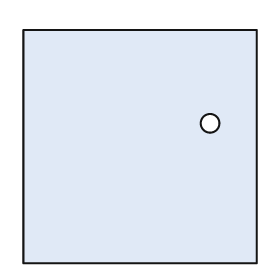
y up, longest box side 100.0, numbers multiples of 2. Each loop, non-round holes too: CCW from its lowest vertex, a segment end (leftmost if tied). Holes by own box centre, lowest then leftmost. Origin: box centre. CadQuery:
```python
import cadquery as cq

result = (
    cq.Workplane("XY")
    .moveTo(-50.0, -50.0)
    .lineTo(50.0, -50.0)
    .lineTo(50.0, 50.0)
    .lineTo(-50.0, 50.0)
    .close()
    .moveTo(30.0, 10.0)
    .circle(4.0)
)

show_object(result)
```